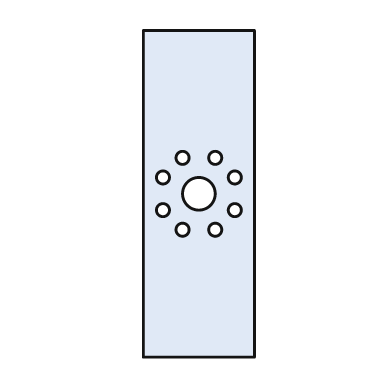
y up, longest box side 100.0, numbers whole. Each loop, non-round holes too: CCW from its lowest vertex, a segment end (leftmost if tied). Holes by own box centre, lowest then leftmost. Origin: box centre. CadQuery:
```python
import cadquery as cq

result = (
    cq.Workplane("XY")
    .moveTo(-17.0, -50.0)
    .lineTo(17.0, -50.0)
    .lineTo(17.0, 50.0)
    .lineTo(-17.0, 50.0)
    .close()
    .moveTo(-5.0, -11.0)
    .circle(2.0)
    .moveTo(5.0, -11.0)
    .circle(2.0)
    .moveTo(-11.0, -5.0)
    .circle(2.0)
    .moveTo(11.0, -5.0)
    .circle(2.0)
    .moveTo(0.0, 0.0)
    .circle(5.0)
    .moveTo(-11.0, 5.0)
    .circle(2.0)
    .moveTo(11.0, 5.0)
    .circle(2.0)
    .moveTo(-5.0, 11.0)
    .circle(2.0)
    .moveTo(5.0, 11.0)
    .circle(2.0)
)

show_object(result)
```